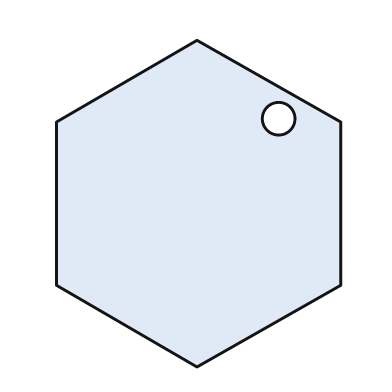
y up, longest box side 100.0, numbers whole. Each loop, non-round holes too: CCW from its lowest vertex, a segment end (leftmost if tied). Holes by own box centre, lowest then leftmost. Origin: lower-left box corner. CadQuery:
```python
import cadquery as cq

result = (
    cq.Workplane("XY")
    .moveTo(43.0, 0.0)
    .lineTo(87.0, 25.0)
    .lineTo(87.0, 75.0)
    .lineTo(43.0, 100.0)
    .lineTo(0.0, 75.0)
    .lineTo(0.0, 25.0)
    .close()
    .moveTo(68.0, 76.0)
    .circle(5.0)
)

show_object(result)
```